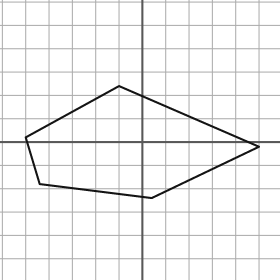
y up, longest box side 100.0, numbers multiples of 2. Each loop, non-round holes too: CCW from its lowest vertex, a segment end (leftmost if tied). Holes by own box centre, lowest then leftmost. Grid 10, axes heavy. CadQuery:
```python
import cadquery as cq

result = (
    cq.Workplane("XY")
    .moveTo(4.0, -24.0)
    .lineTo(50.0, -2.0)
    .lineTo(-10.0, 24.0)
    .lineTo(-50.0, 2.0)
    .lineTo(-44.0, -18.0)
    .close()
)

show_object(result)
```